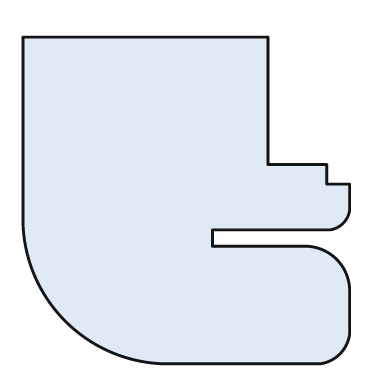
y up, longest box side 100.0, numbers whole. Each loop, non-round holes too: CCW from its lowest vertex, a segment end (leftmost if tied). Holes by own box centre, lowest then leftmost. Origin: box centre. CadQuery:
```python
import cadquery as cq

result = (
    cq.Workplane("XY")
    .moveTo(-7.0, -50.0)
    .lineTo(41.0, -50.0)
    .threePointArc((47.0, -47.0), (50.0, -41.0))
    .lineTo(50.0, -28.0)
    .threePointArc((46.0, -18.0), (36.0, -14.0))
    .lineTo(8.0, -14.0)
    .lineTo(8.0, -9.0)
    .lineTo(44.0, -9.0)
    .threePointArc((48.0, -7.0), (50.0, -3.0))
    .lineTo(50.0, 5.0)
    .lineTo(43.0, 5.0)
    .lineTo(43.0, 11.0)
    .lineTo(25.0, 11.0)
    .lineTo(25.0, 50.0)
    .lineTo(-50.0, 50.0)
    .lineTo(-50.0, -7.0)
    .threePointArc((-37.0, -37.0), (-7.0, -50.0))
    .close()
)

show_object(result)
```